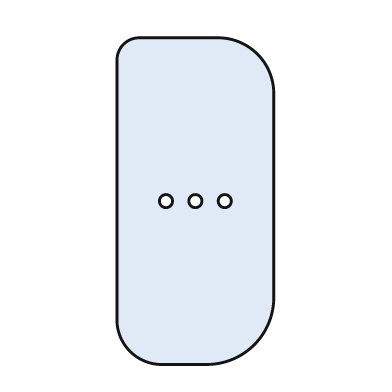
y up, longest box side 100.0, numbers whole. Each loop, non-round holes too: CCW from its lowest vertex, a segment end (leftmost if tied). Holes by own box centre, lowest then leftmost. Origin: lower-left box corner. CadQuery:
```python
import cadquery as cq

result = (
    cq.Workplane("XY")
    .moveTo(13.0, 0.0)
    .lineTo(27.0, 0.0)
    .threePointArc((42.0, 6.0), (48.0, 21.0))
    .lineTo(48.0, 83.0)
    .threePointArc((43.0, 95.0), (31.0, 100.0))
    .lineTo(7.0, 100.0)
    .threePointArc((2.0, 98.0), (0.0, 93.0))
    .lineTo(0.0, 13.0)
    .threePointArc((4.0, 4.0), (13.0, 0.0))
    .close()
    .moveTo(15.0, 50.0)
    .circle(2.0)
    .moveTo(24.0, 50.0)
    .circle(2.0)
    .moveTo(33.0, 50.0)
    .circle(2.0)
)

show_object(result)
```